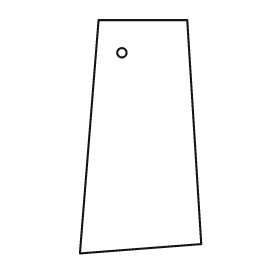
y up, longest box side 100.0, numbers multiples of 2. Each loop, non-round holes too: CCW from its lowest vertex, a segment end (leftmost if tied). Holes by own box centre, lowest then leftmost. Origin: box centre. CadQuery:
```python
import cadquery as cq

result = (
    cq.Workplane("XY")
    .moveTo(-26.0, -50.0)
    .lineTo(26.0, -46.0)
    .lineTo(20.0, 50.0)
    .lineTo(-18.0, 50.0)
    .close()
    .moveTo(-8.0, 36.0)
    .circle(2.0)
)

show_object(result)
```